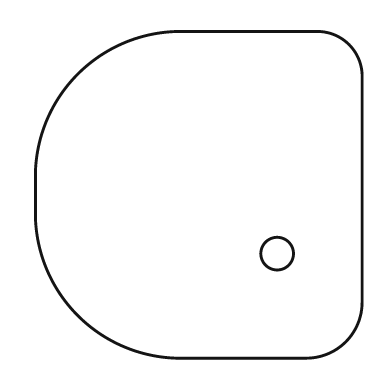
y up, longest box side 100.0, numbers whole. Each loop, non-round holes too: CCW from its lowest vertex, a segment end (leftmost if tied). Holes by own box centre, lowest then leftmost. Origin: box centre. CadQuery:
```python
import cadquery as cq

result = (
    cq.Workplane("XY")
    .moveTo(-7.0, -50.0)
    .lineTo(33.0, -50.0)
    .threePointArc((45.0, -45.0), (50.0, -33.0))
    .lineTo(50.0, 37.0)
    .threePointArc((46.0, 46.0), (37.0, 50.0))
    .lineTo(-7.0, 50.0)
    .threePointArc((-37.0, 37.0), (-50.0, 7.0))
    .lineTo(-50.0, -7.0)
    .threePointArc((-37.0, -37.0), (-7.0, -50.0))
    .close()
    .moveTo(24.0, -18.0)
    .circle(5.0)
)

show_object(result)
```